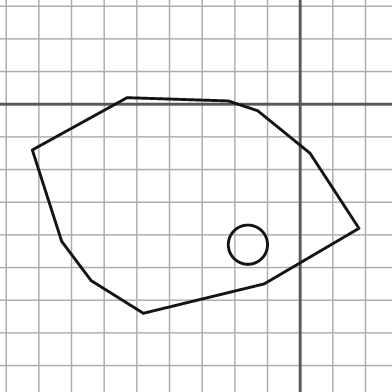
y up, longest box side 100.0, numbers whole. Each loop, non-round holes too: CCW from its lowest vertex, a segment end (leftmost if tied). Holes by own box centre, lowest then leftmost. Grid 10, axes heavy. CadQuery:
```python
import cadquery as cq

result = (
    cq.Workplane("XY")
    .moveTo(-48.0, -64.0)
    .lineTo(-11.0, -55.0)
    .lineTo(18.0, -38.0)
    .lineTo(3.0, -15.0)
    .lineTo(-13.0, -2.0)
    .lineTo(-22.0, 1.0)
    .lineTo(-53.0, 2.0)
    .lineTo(-82.0, -14.0)
    .lineTo(-73.0, -42.0)
    .lineTo(-64.0, -54.0)
    .close()
    .moveTo(-16.0, -43.0)
    .circle(6.0)
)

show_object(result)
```